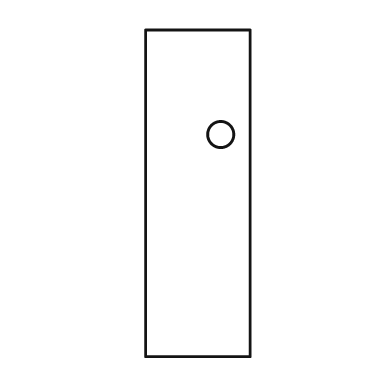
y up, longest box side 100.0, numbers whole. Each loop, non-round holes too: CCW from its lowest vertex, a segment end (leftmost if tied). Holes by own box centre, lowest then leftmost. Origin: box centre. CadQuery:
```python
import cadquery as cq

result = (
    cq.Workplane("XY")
    .moveTo(-16.0, -50.0)
    .lineTo(16.0, -50.0)
    .lineTo(16.0, 50.0)
    .lineTo(-16.0, 50.0)
    .close()
    .moveTo(7.0, 18.0)
    .circle(4.0)
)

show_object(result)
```